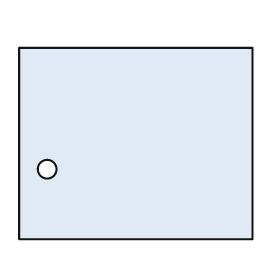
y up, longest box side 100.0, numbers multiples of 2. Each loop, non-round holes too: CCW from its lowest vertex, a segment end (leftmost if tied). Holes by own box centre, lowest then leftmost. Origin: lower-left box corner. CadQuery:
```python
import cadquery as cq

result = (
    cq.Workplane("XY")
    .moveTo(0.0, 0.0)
    .lineTo(100.0, 0.0)
    .lineTo(100.0, 82.0)
    .lineTo(0.0, 82.0)
    .close()
    .moveTo(12.0, 30.0)
    .circle(4.0)
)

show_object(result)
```